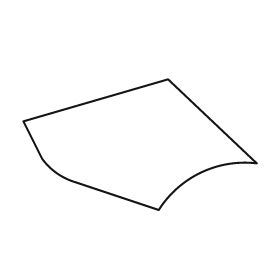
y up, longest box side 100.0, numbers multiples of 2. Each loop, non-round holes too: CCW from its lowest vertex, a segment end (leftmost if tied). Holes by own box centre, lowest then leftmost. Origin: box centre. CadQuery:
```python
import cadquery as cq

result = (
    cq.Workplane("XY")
    .moveTo(8.0, -28.0)
    .threePointArc((26.0, -12.0), (50.0, -8.0))
    .lineTo(12.0, 28.0)
    .lineTo(-50.0, 10.0)
    .lineTo(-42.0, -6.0)
    .threePointArc((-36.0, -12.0), (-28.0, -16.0))
    .close()
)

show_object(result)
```